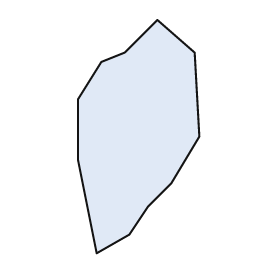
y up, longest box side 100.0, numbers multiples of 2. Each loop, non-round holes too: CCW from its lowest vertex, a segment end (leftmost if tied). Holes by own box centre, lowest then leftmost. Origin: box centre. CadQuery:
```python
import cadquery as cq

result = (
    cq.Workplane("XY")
    .moveTo(-18.0, -50.0)
    .lineTo(-4.0, -42.0)
    .lineTo(4.0, -30.0)
    .lineTo(14.0, -20.0)
    .lineTo(26.0, 0.0)
    .lineTo(24.0, 36.0)
    .lineTo(8.0, 50.0)
    .lineTo(-6.0, 36.0)
    .lineTo(-16.0, 32.0)
    .lineTo(-26.0, 16.0)
    .lineTo(-26.0, -10.0)
    .close()
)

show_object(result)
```